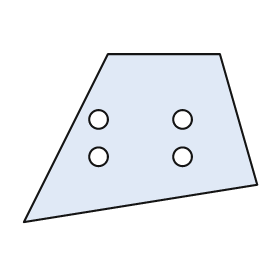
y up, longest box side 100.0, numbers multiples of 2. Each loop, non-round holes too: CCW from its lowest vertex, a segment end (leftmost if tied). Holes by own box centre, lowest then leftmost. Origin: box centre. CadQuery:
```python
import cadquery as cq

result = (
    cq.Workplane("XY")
    .moveTo(-50.0, -36.0)
    .lineTo(50.0, -20.0)
    .lineTo(34.0, 36.0)
    .lineTo(-14.0, 36.0)
    .close()
    .moveTo(-18.0, -8.0)
    .circle(4.0)
    .moveTo(18.0, -8.0)
    .circle(4.0)
    .moveTo(-18.0, 8.0)
    .circle(4.0)
    .moveTo(18.0, 8.0)
    .circle(4.0)
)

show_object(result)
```